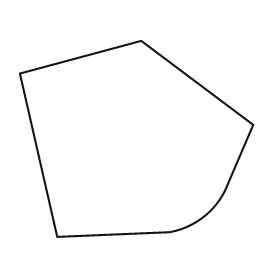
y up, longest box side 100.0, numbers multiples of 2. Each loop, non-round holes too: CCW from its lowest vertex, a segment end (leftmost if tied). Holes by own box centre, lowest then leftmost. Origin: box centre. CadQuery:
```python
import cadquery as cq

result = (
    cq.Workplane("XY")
    .moveTo(-34.0, -42.0)
    .lineTo(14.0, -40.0)
    .threePointArc((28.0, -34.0), (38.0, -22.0))
    .lineTo(50.0, 6.0)
    .lineTo(2.0, 42.0)
    .lineTo(-50.0, 28.0)
    .close()
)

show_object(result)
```